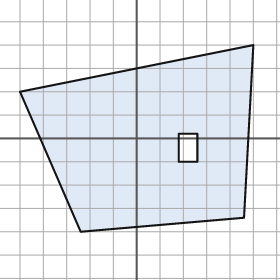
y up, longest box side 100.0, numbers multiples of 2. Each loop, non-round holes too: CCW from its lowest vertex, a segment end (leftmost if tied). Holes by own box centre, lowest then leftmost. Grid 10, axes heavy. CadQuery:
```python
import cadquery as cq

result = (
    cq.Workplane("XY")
    .moveTo(-24.0, -40.0)
    .lineTo(46.0, -34.0)
    .lineTo(50.0, 40.0)
    .lineTo(-50.0, 20.0)
    .close()
    .moveTo(18.0, -10.0)
    .lineTo(26.0, -10.0)
    .lineTo(26.0, 2.0)
    .lineTo(18.0, 2.0)
    .close()
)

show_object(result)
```